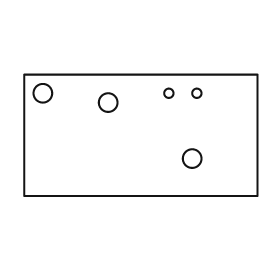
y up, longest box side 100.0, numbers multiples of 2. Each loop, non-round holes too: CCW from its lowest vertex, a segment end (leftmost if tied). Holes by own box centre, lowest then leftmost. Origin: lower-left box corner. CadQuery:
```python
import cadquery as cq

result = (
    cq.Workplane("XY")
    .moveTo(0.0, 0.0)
    .lineTo(100.0, 0.0)
    .lineTo(100.0, 52.0)
    .lineTo(0.0, 52.0)
    .close()
    .moveTo(72.0, 16.0)
    .circle(4.0)
    .moveTo(36.0, 40.0)
    .circle(4.0)
    .moveTo(8.0, 44.0)
    .circle(4.0)
    .moveTo(62.0, 44.0)
    .circle(2.0)
    .moveTo(74.0, 44.0)
    .circle(2.0)
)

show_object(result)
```